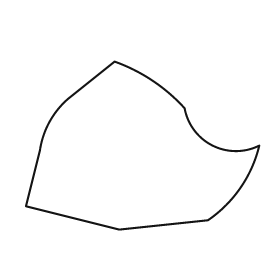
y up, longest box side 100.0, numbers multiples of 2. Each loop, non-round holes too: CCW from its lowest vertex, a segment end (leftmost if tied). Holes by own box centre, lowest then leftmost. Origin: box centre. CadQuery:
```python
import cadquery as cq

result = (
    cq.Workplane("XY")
    .moveTo(-10.0, -36.0)
    .lineTo(28.0, -32.0)
    .threePointArc((42.0, -18.0), (50.0, 0.0))
    .threePointArc((30.0, 0.0), (18.0, 16.0))
    .threePointArc((4.0, 28.0), (-12.0, 36.0))
    .lineTo(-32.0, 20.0)
    .threePointArc((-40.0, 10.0), (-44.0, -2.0))
    .lineTo(-50.0, -26.0)
    .close()
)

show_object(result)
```